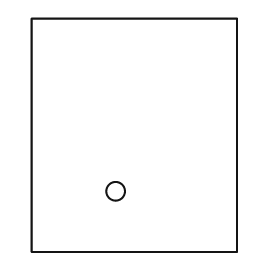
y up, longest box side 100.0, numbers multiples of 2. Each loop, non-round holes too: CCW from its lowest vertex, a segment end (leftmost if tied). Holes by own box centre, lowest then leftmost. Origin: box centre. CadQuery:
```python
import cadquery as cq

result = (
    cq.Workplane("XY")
    .moveTo(-44.0, -50.0)
    .lineTo(44.0, -50.0)
    .lineTo(44.0, 50.0)
    .lineTo(-44.0, 50.0)
    .close()
    .moveTo(-8.0, -24.0)
    .circle(4.0)
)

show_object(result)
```